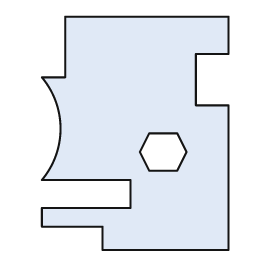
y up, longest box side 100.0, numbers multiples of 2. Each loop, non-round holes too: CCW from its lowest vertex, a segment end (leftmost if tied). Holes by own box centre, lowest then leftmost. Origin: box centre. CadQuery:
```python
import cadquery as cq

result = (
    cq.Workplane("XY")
    .moveTo(-14.0, -50.0)
    .lineTo(40.0, -50.0)
    .lineTo(40.0, 12.0)
    .lineTo(26.0, 12.0)
    .lineTo(26.0, 34.0)
    .lineTo(40.0, 34.0)
    .lineTo(40.0, 50.0)
    .lineTo(-30.0, 50.0)
    .lineTo(-30.0, 24.0)
    .lineTo(-40.0, 24.0)
    .threePointArc((-32.0, 2.0), (-40.0, -20.0))
    .lineTo(-2.0, -20.0)
    .lineTo(-2.0, -32.0)
    .lineTo(-40.0, -32.0)
    .lineTo(-40.0, -40.0)
    .lineTo(-14.0, -40.0)
    .close()
    .moveTo(6.0, -16.0)
    .lineTo(18.0, -16.0)
    .lineTo(22.0, -8.0)
    .lineTo(18.0, 0.0)
    .lineTo(6.0, 0.0)
    .lineTo(2.0, -8.0)
    .close()
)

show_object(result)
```